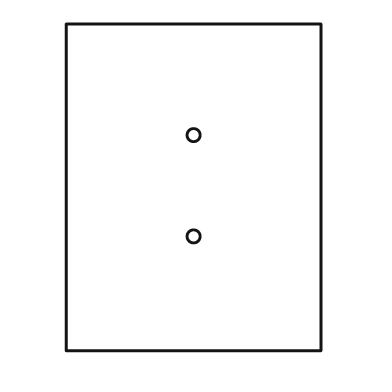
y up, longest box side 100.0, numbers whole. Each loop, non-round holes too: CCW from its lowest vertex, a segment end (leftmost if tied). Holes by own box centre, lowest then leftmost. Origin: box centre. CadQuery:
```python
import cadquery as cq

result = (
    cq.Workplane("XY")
    .moveTo(-39.0, -50.0)
    .lineTo(39.0, -50.0)
    .lineTo(39.0, 50.0)
    .lineTo(-39.0, 50.0)
    .close()
    .moveTo(0.0, -15.0)
    .circle(2.0)
    .moveTo(0.0, 16.0)
    .circle(2.0)
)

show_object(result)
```